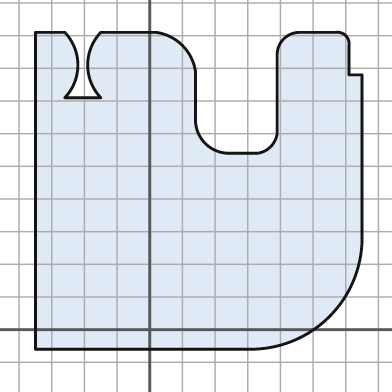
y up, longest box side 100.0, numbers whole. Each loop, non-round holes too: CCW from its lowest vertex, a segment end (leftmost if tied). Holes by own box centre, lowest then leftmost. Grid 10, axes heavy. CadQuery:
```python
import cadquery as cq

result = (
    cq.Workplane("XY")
    .moveTo(-35.0, -6.0)
    .lineTo(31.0, -6.0)
    .threePointArc((55.0, 4.0), (65.0, 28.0))
    .lineTo(65.0, 78.0)
    .lineTo(61.0, 78.0)
    .lineTo(61.0, 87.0)
    .threePointArc((60.0, 90.0), (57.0, 91.0))
    .lineTo(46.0, 91.0)
    .threePointArc((41.0, 89.0), (39.0, 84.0))
    .lineTo(39.0, 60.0)
    .threePointArc((37.0, 56.0), (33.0, 54.0))
    .lineTo(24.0, 54.0)
    .threePointArc((17.0, 57.0), (14.0, 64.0))
    .lineTo(14.0, 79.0)
    .threePointArc((10.0, 87.0), (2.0, 91.0))
    .lineTo(-15.0, 91.0)
    .threePointArc((-19.0, 81.0), (-15.0, 71.0))
    .lineTo(-26.0, 71.0)
    .threePointArc((-22.0, 81.0), (-26.0, 91.0))
    .lineTo(-35.0, 91.0)
    .close()
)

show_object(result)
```